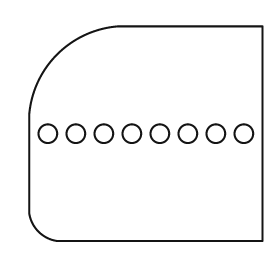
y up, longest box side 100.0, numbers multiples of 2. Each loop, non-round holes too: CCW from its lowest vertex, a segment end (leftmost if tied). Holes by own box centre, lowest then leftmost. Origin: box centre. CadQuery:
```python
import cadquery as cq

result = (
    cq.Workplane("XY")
    .moveTo(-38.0, -46.0)
    .lineTo(50.0, -46.0)
    .lineTo(50.0, 46.0)
    .lineTo(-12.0, 46.0)
    .threePointArc((-38.0, 34.0), (-50.0, 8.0))
    .lineTo(-50.0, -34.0)
    .threePointArc((-46.0, -42.0), (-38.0, -46.0))
    .close()
    .moveTo(-42.0, 0.0)
    .circle(4.0)
    .moveTo(-30.0, 0.0)
    .circle(4.0)
    .moveTo(-18.0, 0.0)
    .circle(4.0)
    .moveTo(-6.0, 0.0)
    .circle(4.0)
    .moveTo(6.0, 0.0)
    .circle(4.0)
    .moveTo(18.0, 0.0)
    .circle(4.0)
    .moveTo(30.0, 0.0)
    .circle(4.0)
    .moveTo(42.0, 0.0)
    .circle(4.0)
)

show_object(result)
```